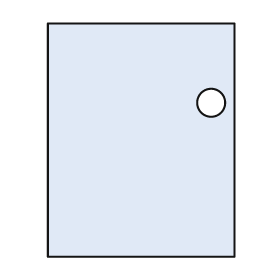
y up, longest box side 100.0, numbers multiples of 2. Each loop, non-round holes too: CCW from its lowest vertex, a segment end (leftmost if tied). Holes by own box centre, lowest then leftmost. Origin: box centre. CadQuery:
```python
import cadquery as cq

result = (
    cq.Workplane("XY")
    .moveTo(-40.0, -50.0)
    .lineTo(40.0, -50.0)
    .lineTo(40.0, 50.0)
    .lineTo(-40.0, 50.0)
    .close()
    .moveTo(30.0, 16.0)
    .circle(6.0)
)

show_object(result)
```